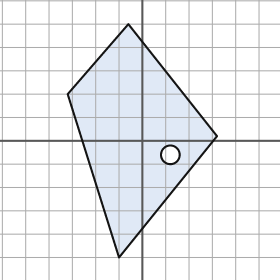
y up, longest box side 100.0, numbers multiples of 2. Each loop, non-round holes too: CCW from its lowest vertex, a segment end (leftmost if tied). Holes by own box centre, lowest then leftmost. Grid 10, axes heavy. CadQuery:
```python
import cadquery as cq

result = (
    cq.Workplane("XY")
    .moveTo(-10.0, -50.0)
    .lineTo(32.0, 2.0)
    .lineTo(-6.0, 50.0)
    .lineTo(-32.0, 20.0)
    .close()
    .moveTo(12.0, -6.0)
    .circle(4.0)
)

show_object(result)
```